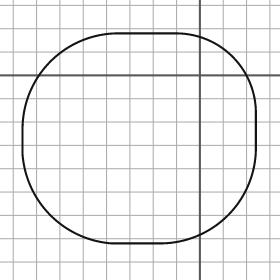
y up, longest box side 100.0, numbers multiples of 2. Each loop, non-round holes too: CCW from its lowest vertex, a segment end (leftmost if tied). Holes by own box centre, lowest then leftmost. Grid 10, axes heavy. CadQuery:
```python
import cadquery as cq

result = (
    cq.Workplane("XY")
    .moveTo(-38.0, -72.0)
    .lineTo(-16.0, -72.0)
    .threePointArc((12.0, -60.0), (24.0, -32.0))
    .lineTo(24.0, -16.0)
    .threePointArc((14.0, 8.0), (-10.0, 18.0))
    .lineTo(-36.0, 18.0)
    .threePointArc((-64.0, 6.0), (-76.0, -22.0))
    .lineTo(-76.0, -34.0)
    .threePointArc((-64.0, -60.0), (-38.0, -72.0))
    .close()
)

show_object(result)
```